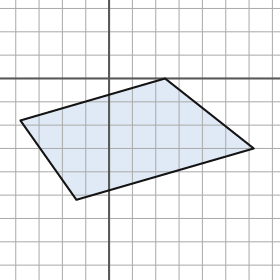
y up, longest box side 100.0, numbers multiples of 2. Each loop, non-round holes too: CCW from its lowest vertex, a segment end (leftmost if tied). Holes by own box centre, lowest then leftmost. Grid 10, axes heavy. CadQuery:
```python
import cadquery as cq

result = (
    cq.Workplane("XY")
    .moveTo(-14.0, -52.0)
    .lineTo(62.0, -30.0)
    .lineTo(24.0, 0.0)
    .lineTo(-38.0, -18.0)
    .close()
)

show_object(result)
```